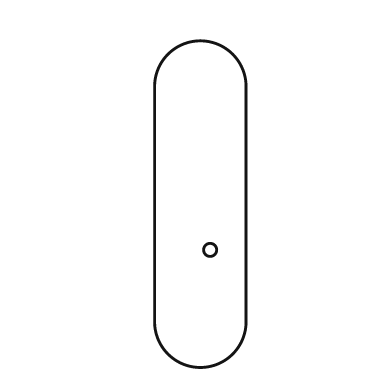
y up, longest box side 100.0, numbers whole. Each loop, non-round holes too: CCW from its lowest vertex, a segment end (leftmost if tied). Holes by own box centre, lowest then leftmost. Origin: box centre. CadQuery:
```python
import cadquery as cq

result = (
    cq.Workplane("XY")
    .moveTo(-14.0, -36.0)
    .threePointArc((0.0, -50.0), (14.0, -36.0))
    .lineTo(14.0, 36.0)
    .threePointArc((0.0, 50.0), (-14.0, 36.0))
    .close()
    .moveTo(3.0, -14.0)
    .circle(2.0)
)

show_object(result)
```